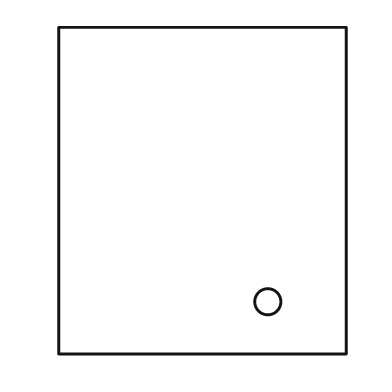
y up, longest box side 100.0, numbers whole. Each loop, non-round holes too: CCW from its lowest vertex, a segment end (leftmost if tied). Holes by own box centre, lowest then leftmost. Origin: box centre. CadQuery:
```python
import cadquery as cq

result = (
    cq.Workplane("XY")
    .moveTo(-44.0, -50.0)
    .lineTo(44.0, -50.0)
    .lineTo(44.0, 50.0)
    .lineTo(-44.0, 50.0)
    .close()
    .moveTo(20.0, -34.0)
    .circle(4.0)
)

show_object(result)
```